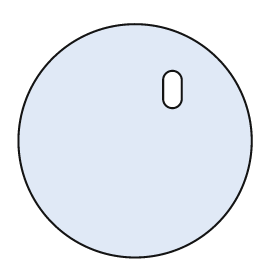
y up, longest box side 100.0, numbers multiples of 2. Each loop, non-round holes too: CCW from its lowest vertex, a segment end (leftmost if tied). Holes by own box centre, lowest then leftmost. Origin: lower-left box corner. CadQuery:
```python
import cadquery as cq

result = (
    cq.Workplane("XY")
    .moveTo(50.0, 50.0)
    .circle(50.0)
    .moveTo(62.0, 68.0)
    .threePointArc((66.0, 64.0), (70.0, 68.0))
    .lineTo(70.0, 76.0)
    .threePointArc((66.0, 80.0), (62.0, 76.0))
    .close()
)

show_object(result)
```